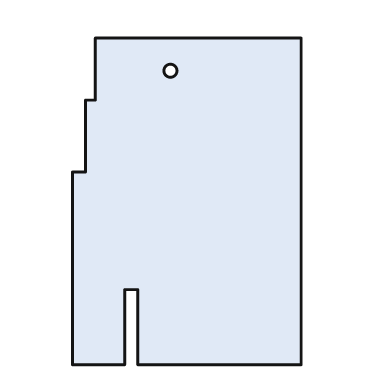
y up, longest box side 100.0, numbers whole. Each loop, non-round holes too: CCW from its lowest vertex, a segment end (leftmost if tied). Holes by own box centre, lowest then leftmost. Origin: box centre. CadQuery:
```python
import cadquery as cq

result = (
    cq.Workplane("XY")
    .moveTo(-35.0, -50.0)
    .lineTo(-19.0, -50.0)
    .lineTo(-19.0, -27.0)
    .lineTo(-15.0, -27.0)
    .lineTo(-15.0, -50.0)
    .lineTo(35.0, -50.0)
    .lineTo(35.0, 50.0)
    .lineTo(-28.0, 50.0)
    .lineTo(-28.0, 31.0)
    .lineTo(-31.0, 31.0)
    .lineTo(-31.0, 9.0)
    .lineTo(-35.0, 9.0)
    .close()
    .moveTo(-5.0, 40.0)
    .circle(2.0)
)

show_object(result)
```